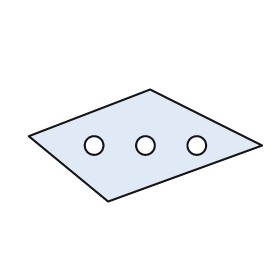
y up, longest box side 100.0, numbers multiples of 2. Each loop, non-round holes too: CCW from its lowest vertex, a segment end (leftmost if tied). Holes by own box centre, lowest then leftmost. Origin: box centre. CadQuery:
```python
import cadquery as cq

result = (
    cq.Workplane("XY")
    .moveTo(-16.0, -24.0)
    .lineTo(50.0, 0.0)
    .lineTo(2.0, 24.0)
    .lineTo(-50.0, 4.0)
    .close()
    .moveTo(-22.0, 0.0)
    .circle(4.0)
    .moveTo(0.0, 0.0)
    .circle(4.0)
    .moveTo(22.0, 0.0)
    .circle(4.0)
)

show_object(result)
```